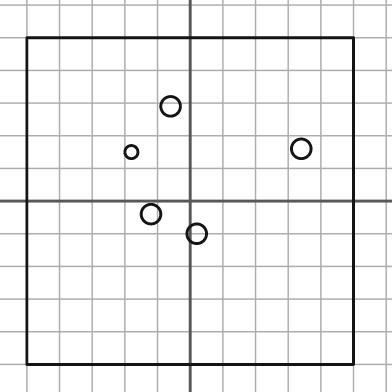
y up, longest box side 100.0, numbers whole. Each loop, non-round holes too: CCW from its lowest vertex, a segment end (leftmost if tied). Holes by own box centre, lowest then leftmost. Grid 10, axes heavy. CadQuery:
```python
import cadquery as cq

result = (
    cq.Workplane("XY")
    .moveTo(-50.0, -50.0)
    .lineTo(50.0, -50.0)
    .lineTo(50.0, 50.0)
    .lineTo(-50.0, 50.0)
    .close()
    .moveTo(2.0, -10.0)
    .circle(3.0)
    .moveTo(-12.0, -4.0)
    .circle(3.0)
    .moveTo(-18.0, 15.0)
    .circle(2.0)
    .moveTo(34.0, 16.0)
    .circle(3.0)
    .moveTo(-6.0, 29.0)
    .circle(3.0)
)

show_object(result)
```